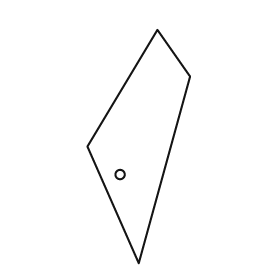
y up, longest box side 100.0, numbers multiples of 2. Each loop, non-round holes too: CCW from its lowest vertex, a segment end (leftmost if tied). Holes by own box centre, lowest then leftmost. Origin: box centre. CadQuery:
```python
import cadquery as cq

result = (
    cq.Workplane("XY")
    .moveTo(0.0, -50.0)
    .lineTo(22.0, 30.0)
    .lineTo(8.0, 50.0)
    .lineTo(-22.0, 0.0)
    .close()
    .moveTo(-8.0, -12.0)
    .circle(2.0)
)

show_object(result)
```